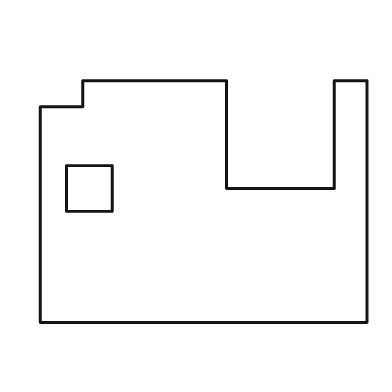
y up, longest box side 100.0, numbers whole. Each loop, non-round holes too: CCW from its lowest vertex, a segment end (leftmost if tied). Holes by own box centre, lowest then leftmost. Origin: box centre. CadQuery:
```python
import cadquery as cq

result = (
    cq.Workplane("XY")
    .moveTo(-50.0, -37.0)
    .lineTo(50.0, -37.0)
    .lineTo(50.0, 37.0)
    .lineTo(40.0, 37.0)
    .lineTo(40.0, 4.0)
    .lineTo(7.0, 4.0)
    .lineTo(7.0, 37.0)
    .lineTo(-37.0, 37.0)
    .lineTo(-37.0, 29.0)
    .lineTo(-50.0, 29.0)
    .close()
    .moveTo(-42.0, -3.0)
    .lineTo(-28.0, -3.0)
    .lineTo(-28.0, 11.0)
    .lineTo(-42.0, 11.0)
    .close()
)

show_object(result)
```